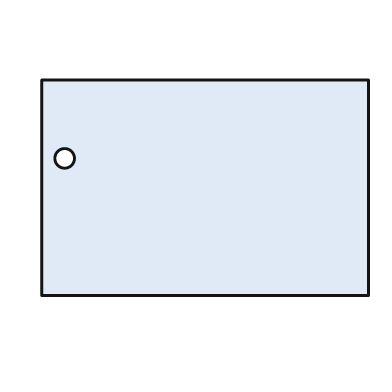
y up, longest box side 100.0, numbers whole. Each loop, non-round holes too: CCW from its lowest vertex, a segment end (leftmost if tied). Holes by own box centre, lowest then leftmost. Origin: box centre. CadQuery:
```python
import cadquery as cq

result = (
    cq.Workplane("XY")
    .moveTo(-50.0, -33.0)
    .lineTo(50.0, -33.0)
    .lineTo(50.0, 33.0)
    .lineTo(-50.0, 33.0)
    .close()
    .moveTo(-43.0, 9.0)
    .circle(3.0)
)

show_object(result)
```